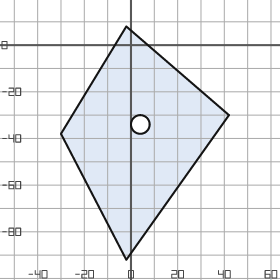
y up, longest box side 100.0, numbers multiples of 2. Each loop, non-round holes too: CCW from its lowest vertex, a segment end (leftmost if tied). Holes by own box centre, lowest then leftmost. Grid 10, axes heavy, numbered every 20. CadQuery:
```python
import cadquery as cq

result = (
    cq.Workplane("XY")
    .moveTo(-2.0, -92.0)
    .lineTo(42.0, -30.0)
    .lineTo(-2.0, 8.0)
    .lineTo(-30.0, -38.0)
    .close()
    .moveTo(4.0, -34.0)
    .circle(4.0)
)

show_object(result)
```